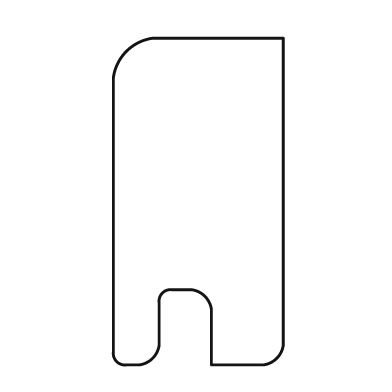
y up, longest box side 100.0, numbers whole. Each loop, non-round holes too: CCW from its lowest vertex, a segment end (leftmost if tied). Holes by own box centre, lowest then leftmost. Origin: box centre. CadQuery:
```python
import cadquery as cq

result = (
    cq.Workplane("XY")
    .moveTo(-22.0, -50.0)
    .lineTo(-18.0, -50.0)
    .threePointArc((-14.0, -48.0), (-12.0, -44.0))
    .lineTo(-12.0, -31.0)
    .threePointArc((-11.0, -28.0), (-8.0, -27.0))
    .lineTo(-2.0, -27.0)
    .threePointArc((2.0, -29.0), (4.0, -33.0))
    .lineTo(4.0, -50.0)
    .lineTo(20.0, -50.0)
    .threePointArc((24.0, -48.0), (26.0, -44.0))
    .lineTo(26.0, 50.0)
    .lineTo(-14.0, 50.0)
    .threePointArc((-22.0, 46.0), (-26.0, 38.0))
    .lineTo(-26.0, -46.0)
    .threePointArc((-25.0, -49.0), (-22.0, -50.0))
    .close()
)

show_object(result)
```